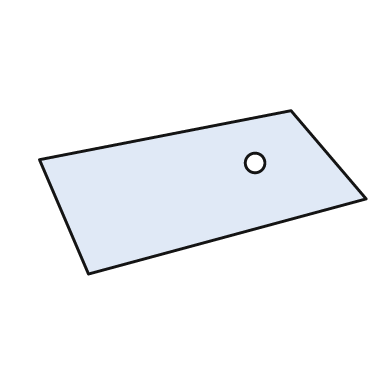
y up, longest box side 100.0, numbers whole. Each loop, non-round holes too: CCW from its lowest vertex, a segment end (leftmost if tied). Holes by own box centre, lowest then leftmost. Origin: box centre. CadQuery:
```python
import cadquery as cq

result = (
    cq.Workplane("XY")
    .moveTo(-35.0, -25.0)
    .lineTo(50.0, -2.0)
    .lineTo(27.0, 25.0)
    .lineTo(-50.0, 10.0)
    .close()
    .moveTo(16.0, 9.0)
    .circle(3.0)
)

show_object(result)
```